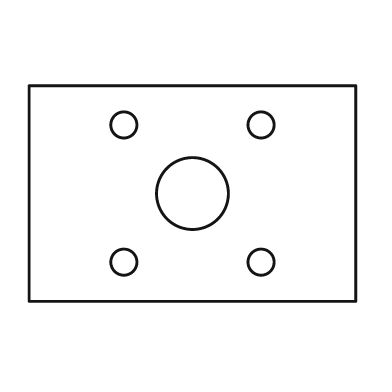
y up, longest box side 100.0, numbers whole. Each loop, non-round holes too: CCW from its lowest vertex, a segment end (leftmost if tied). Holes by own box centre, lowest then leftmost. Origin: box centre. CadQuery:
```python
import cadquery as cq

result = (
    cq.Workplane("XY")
    .moveTo(-50.0, -33.0)
    .lineTo(50.0, -33.0)
    .lineTo(50.0, 33.0)
    .lineTo(-50.0, 33.0)
    .close()
    .moveTo(-21.0, -21.0)
    .circle(4.0)
    .moveTo(21.0, -21.0)
    .circle(4.0)
    .moveTo(0.0, 0.0)
    .circle(11.0)
    .moveTo(-21.0, 21.0)
    .circle(4.0)
    .moveTo(21.0, 21.0)
    .circle(4.0)
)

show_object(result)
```